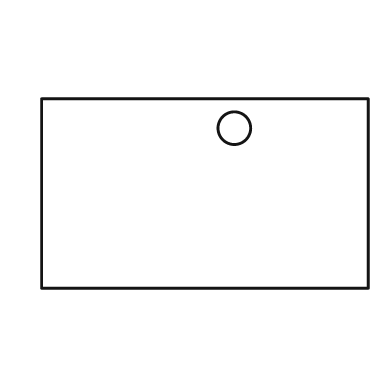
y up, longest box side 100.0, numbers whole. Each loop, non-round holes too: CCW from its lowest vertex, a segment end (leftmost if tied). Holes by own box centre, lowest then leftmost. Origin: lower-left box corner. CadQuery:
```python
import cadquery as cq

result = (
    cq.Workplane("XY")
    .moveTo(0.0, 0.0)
    .lineTo(100.0, 0.0)
    .lineTo(100.0, 58.0)
    .lineTo(0.0, 58.0)
    .close()
    .moveTo(59.0, 49.0)
    .circle(5.0)
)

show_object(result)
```